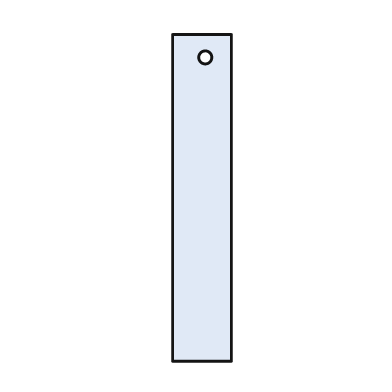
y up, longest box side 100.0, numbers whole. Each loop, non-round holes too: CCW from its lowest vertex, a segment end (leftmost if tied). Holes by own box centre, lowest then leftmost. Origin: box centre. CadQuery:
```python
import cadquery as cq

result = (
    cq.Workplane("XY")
    .moveTo(-9.0, -50.0)
    .lineTo(9.0, -50.0)
    .lineTo(9.0, 50.0)
    .lineTo(-9.0, 50.0)
    .close()
    .moveTo(1.0, 43.0)
    .circle(2.0)
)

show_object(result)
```